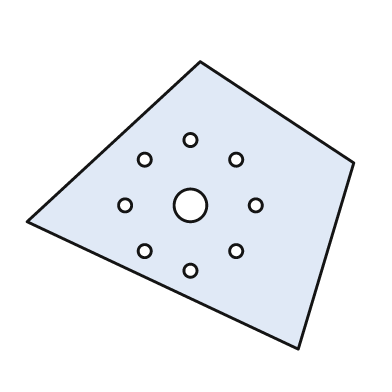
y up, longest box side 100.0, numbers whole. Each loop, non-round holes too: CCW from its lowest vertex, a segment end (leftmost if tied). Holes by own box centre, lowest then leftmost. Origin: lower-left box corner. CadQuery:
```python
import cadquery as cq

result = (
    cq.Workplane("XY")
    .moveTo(83.0, 0.0)
    .lineTo(100.0, 57.0)
    .lineTo(53.0, 88.0)
    .lineTo(0.0, 39.0)
    .close()
    .moveTo(50.0, 24.0)
    .circle(2.0)
    .moveTo(36.0, 30.0)
    .circle(2.0)
    .moveTo(64.0, 30.0)
    .circle(2.0)
    .moveTo(30.0, 44.0)
    .circle(2.0)
    .moveTo(50.0, 44.0)
    .circle(5.0)
    .moveTo(70.0, 44.0)
    .circle(2.0)
    .moveTo(36.0, 58.0)
    .circle(2.0)
    .moveTo(64.0, 58.0)
    .circle(2.0)
    .moveTo(50.0, 64.0)
    .circle(2.0)
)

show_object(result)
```